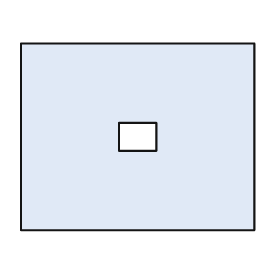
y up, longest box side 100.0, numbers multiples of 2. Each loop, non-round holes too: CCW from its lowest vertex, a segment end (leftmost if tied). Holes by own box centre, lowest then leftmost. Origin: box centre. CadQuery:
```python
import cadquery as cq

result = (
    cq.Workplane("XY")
    .moveTo(-50.0, -40.0)
    .lineTo(50.0, -40.0)
    .lineTo(50.0, 40.0)
    .lineTo(-50.0, 40.0)
    .close()
    .moveTo(-8.0, -6.0)
    .lineTo(8.0, -6.0)
    .lineTo(8.0, 6.0)
    .lineTo(-8.0, 6.0)
    .close()
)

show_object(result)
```